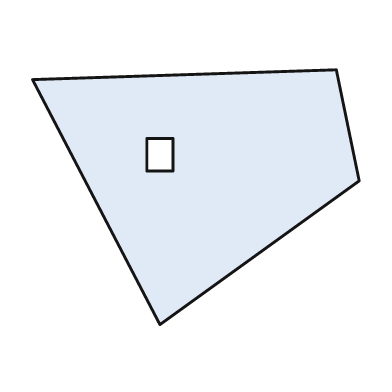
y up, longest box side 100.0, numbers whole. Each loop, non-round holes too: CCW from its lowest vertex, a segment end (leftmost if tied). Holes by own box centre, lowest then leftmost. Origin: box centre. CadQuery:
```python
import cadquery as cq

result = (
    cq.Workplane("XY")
    .moveTo(-11.0, -39.0)
    .lineTo(50.0, 5.0)
    .lineTo(43.0, 39.0)
    .lineTo(-50.0, 36.0)
    .close()
    .moveTo(-15.0, 8.0)
    .lineTo(-7.0, 8.0)
    .lineTo(-7.0, 18.0)
    .lineTo(-15.0, 18.0)
    .close()
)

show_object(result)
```